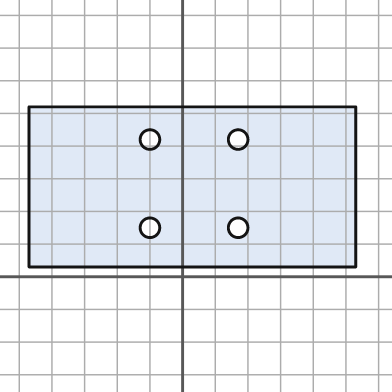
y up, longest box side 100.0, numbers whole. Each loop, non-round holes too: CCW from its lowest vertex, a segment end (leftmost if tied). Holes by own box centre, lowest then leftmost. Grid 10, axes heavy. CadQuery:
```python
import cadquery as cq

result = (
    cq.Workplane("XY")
    .moveTo(-47.0, 3.0)
    .lineTo(53.0, 3.0)
    .lineTo(53.0, 52.0)
    .lineTo(-47.0, 52.0)
    .close()
    .moveTo(-10.0, 15.0)
    .circle(3.0)
    .moveTo(17.0, 15.0)
    .circle(3.0)
    .moveTo(-10.0, 42.0)
    .circle(3.0)
    .moveTo(17.0, 42.0)
    .circle(3.0)
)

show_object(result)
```